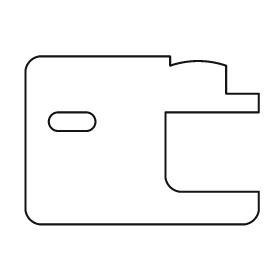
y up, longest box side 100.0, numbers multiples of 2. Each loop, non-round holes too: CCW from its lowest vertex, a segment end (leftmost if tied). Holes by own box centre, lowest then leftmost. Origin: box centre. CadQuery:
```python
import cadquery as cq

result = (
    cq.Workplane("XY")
    .moveTo(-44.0, -36.0)
    .lineTo(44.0, -36.0)
    .threePointArc((48.0, -34.0), (50.0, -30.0))
    .lineTo(50.0, -22.0)
    .lineTo(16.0, -22.0)
    .threePointArc((12.0, -20.0), (10.0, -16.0))
    .lineTo(10.0, 12.0)
    .lineTo(50.0, 12.0)
    .lineTo(50.0, 20.0)
    .lineTo(36.0, 20.0)
    .lineTo(36.0, 32.0)
    .threePointArc((24.0, 34.0), (12.0, 32.0))
    .lineTo(12.0, 36.0)
    .lineTo(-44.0, 36.0)
    .threePointArc((-48.0, 34.0), (-50.0, 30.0))
    .lineTo(-50.0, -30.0)
    .threePointArc((-48.0, -34.0), (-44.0, -36.0))
    .close()
    .moveTo(-36.0, 4.0)
    .lineTo(-24.0, 4.0)
    .threePointArc((-20.0, 8.0), (-24.0, 12.0))
    .lineTo(-36.0, 12.0)
    .threePointArc((-40.0, 8.0), (-36.0, 4.0))
    .close()
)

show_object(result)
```